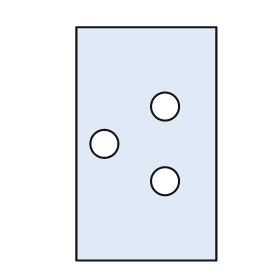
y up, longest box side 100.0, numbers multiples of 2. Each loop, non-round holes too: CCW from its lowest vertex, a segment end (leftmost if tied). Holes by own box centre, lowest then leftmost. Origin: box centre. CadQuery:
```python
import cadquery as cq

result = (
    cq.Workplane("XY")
    .moveTo(-30.0, -50.0)
    .lineTo(30.0, -50.0)
    .lineTo(30.0, 50.0)
    .lineTo(-30.0, 50.0)
    .close()
    .moveTo(8.0, -16.0)
    .circle(6.0)
    .moveTo(-18.0, 0.0)
    .circle(6.0)
    .moveTo(8.0, 16.0)
    .circle(6.0)
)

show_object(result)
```